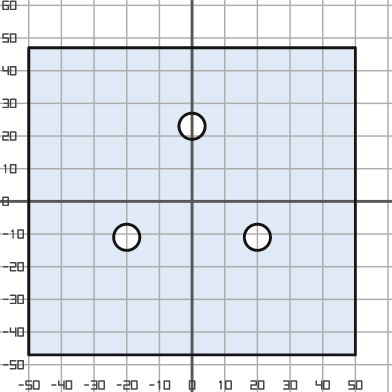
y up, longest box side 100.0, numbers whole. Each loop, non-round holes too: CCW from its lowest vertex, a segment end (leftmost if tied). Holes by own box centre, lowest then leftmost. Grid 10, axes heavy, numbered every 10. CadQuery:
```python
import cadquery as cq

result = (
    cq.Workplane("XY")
    .moveTo(-50.0, -47.0)
    .lineTo(50.0, -47.0)
    .lineTo(50.0, 47.0)
    .lineTo(-50.0, 47.0)
    .close()
    .moveTo(-20.0, -11.0)
    .circle(4.0)
    .moveTo(20.0, -11.0)
    .circle(4.0)
    .moveTo(0.0, 23.0)
    .circle(4.0)
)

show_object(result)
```